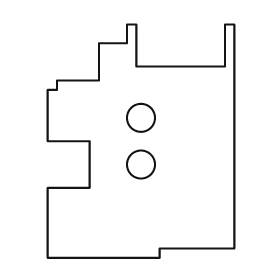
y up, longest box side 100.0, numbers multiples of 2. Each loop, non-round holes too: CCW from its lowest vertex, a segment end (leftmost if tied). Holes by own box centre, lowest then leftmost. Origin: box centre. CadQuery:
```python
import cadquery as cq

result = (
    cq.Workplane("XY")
    .moveTo(-40.0, -50.0)
    .lineTo(8.0, -50.0)
    .lineTo(8.0, -46.0)
    .lineTo(40.0, -46.0)
    .lineTo(40.0, 50.0)
    .lineTo(36.0, 50.0)
    .lineTo(36.0, 32.0)
    .lineTo(-2.0, 32.0)
    .lineTo(-2.0, 50.0)
    .lineTo(-6.0, 50.0)
    .lineTo(-6.0, 42.0)
    .lineTo(-18.0, 42.0)
    .lineTo(-18.0, 26.0)
    .lineTo(-36.0, 26.0)
    .lineTo(-36.0, 22.0)
    .lineTo(-40.0, 22.0)
    .lineTo(-40.0, 0.0)
    .lineTo(-22.0, 0.0)
    .lineTo(-22.0, -20.0)
    .lineTo(-40.0, -20.0)
    .close()
    .moveTo(0.0, -10.0)
    .circle(6.0)
    .moveTo(0.0, 10.0)
    .circle(6.0)
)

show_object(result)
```